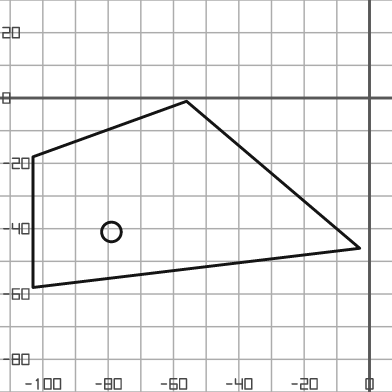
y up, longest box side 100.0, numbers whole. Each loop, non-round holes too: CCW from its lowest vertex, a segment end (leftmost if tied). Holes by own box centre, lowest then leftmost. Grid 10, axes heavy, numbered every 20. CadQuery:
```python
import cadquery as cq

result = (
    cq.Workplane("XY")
    .moveTo(-103.0, -58.0)
    .lineTo(-3.0, -46.0)
    .lineTo(-56.0, -1.0)
    .lineTo(-103.0, -18.0)
    .close()
    .moveTo(-79.0, -41.0)
    .circle(3.0)
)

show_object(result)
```